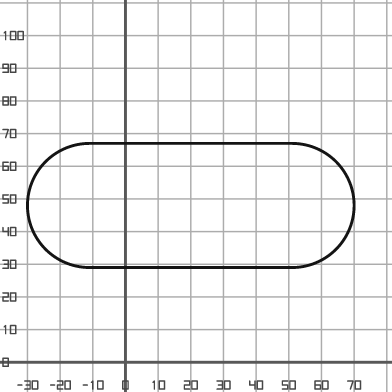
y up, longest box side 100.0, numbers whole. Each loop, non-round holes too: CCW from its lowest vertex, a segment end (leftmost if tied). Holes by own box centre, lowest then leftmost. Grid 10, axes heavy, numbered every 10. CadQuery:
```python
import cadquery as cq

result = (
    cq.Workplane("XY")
    .moveTo(-11.0, 29.0)
    .lineTo(51.0, 29.0)
    .threePointArc((70.0, 48.0), (51.0, 67.0))
    .lineTo(-11.0, 67.0)
    .threePointArc((-30.0, 48.0), (-11.0, 29.0))
    .close()
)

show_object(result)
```